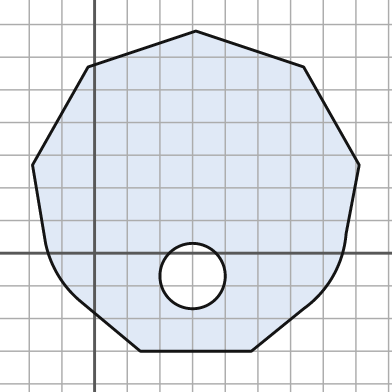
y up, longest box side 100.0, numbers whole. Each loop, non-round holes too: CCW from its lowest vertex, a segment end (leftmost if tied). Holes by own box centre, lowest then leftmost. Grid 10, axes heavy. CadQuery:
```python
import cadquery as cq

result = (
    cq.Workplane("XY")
    .moveTo(14.0, -30.0)
    .lineTo(48.0, -30.0)
    .lineTo(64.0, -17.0)
    .threePointArc((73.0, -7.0), (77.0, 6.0))
    .lineTo(81.0, 27.0)
    .lineTo(64.0, 57.0)
    .lineTo(31.0, 68.0)
    .lineTo(-2.0, 57.0)
    .lineTo(-19.0, 27.0)
    .lineTo(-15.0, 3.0)
    .threePointArc((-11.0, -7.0), (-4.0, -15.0))
    .close()
    .moveTo(30.0, -7.0)
    .circle(10.0)
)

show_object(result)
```